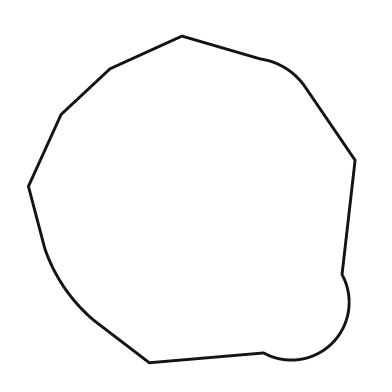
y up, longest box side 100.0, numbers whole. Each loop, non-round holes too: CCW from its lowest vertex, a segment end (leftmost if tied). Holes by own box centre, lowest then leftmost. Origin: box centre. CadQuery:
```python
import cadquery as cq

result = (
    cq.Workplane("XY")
    .moveTo(-13.0, -50.0)
    .lineTo(22.0, -47.0)
    .threePointArc((43.0, -44.0), (46.0, -23.0))
    .lineTo(50.0, 12.0)
    .lineTo(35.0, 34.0)
    .threePointArc((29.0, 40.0), (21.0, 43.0))
    .lineTo(-3.0, 50.0)
    .lineTo(-25.0, 40.0)
    .lineTo(-40.0, 26.0)
    .lineTo(-50.0, 4.0)
    .lineTo(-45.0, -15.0)
    .threePointArc((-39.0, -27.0), (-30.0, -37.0))
    .close()
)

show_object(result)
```